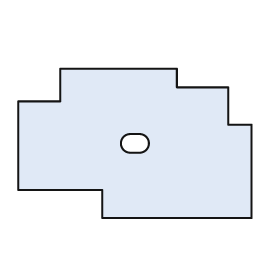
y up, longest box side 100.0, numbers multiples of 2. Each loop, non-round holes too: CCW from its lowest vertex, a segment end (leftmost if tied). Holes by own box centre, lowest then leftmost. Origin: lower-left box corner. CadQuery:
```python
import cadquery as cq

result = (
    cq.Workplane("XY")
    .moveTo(36.0, 0.0)
    .lineTo(100.0, 0.0)
    .lineTo(100.0, 40.0)
    .lineTo(90.0, 40.0)
    .lineTo(90.0, 56.0)
    .lineTo(68.0, 56.0)
    .lineTo(68.0, 64.0)
    .lineTo(18.0, 64.0)
    .lineTo(18.0, 50.0)
    .lineTo(0.0, 50.0)
    .lineTo(0.0, 12.0)
    .lineTo(36.0, 12.0)
    .close()
    .moveTo(48.0, 28.0)
    .lineTo(52.0, 28.0)
    .threePointArc((56.0, 32.0), (52.0, 36.0))
    .lineTo(48.0, 36.0)
    .threePointArc((44.0, 32.0), (48.0, 28.0))
    .close()
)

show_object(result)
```